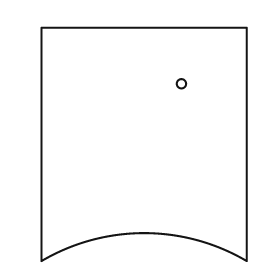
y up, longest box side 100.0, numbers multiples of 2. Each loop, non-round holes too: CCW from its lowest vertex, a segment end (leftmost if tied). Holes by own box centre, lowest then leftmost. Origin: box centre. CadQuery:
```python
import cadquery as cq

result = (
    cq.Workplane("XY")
    .moveTo(-44.0, -50.0)
    .threePointArc((0.0, -38.0), (44.0, -50.0))
    .lineTo(44.0, 50.0)
    .lineTo(-44.0, 50.0)
    .close()
    .moveTo(16.0, 26.0)
    .circle(2.0)
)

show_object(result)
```